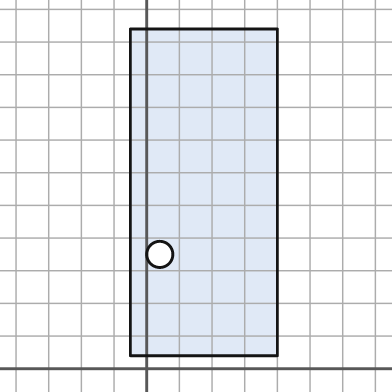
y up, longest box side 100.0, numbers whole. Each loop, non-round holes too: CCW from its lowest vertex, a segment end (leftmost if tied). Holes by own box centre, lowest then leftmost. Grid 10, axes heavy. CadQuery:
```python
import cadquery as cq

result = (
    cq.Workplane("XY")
    .moveTo(-5.0, 4.0)
    .lineTo(40.0, 4.0)
    .lineTo(40.0, 104.0)
    .lineTo(-5.0, 104.0)
    .close()
    .moveTo(4.0, 35.0)
    .circle(4.0)
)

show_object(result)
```